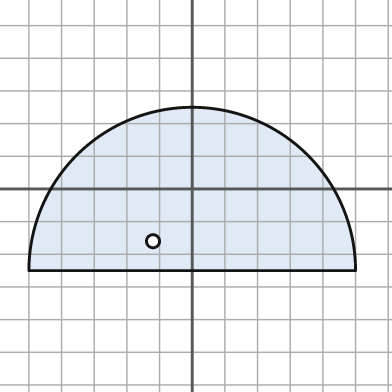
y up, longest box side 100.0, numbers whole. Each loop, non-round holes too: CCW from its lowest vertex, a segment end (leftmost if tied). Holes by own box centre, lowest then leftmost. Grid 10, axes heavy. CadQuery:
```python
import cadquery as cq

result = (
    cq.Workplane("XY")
    .moveTo(-50.0, -25.0)
    .lineTo(50.0, -25.0)
    .threePointArc((0.0, 25.0), (-50.0, -25.0))
    .close()
    .moveTo(-12.0, -16.0)
    .circle(2.0)
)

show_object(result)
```